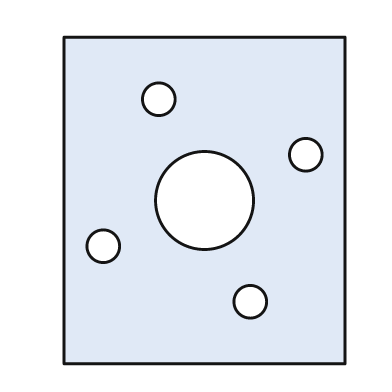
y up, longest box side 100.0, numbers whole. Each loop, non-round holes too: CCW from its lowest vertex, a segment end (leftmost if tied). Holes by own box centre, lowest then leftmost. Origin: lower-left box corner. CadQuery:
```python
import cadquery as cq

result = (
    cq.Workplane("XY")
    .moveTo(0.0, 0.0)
    .lineTo(86.0, 0.0)
    .lineTo(86.0, 100.0)
    .lineTo(0.0, 100.0)
    .close()
    .moveTo(57.0, 19.0)
    .circle(5.0)
    .moveTo(12.0, 36.0)
    .circle(5.0)
    .moveTo(43.0, 50.0)
    .circle(15.0)
    .moveTo(74.0, 64.0)
    .circle(5.0)
    .moveTo(29.0, 81.0)
    .circle(5.0)
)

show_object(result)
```